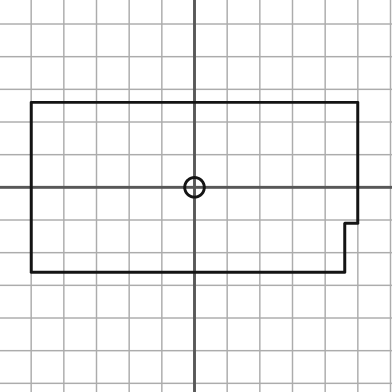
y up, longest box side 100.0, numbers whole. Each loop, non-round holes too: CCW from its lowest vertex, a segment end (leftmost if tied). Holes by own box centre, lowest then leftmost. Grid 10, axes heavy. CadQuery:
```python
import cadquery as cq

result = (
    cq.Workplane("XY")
    .moveTo(-50.0, -26.0)
    .lineTo(46.0, -26.0)
    .lineTo(46.0, -11.0)
    .lineTo(50.0, -11.0)
    .lineTo(50.0, 26.0)
    .lineTo(-50.0, 26.0)
    .close()
    .moveTo(0.0, 0.0)
    .circle(3.0)
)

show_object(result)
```